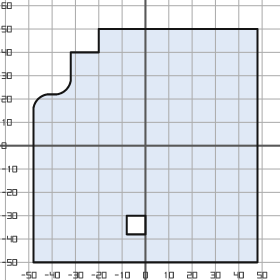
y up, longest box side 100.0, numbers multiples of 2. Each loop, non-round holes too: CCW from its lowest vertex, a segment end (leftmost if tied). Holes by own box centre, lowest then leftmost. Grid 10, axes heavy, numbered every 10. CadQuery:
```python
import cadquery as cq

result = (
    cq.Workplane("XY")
    .moveTo(-48.0, -50.0)
    .lineTo(48.0, -50.0)
    .lineTo(48.0, 50.0)
    .lineTo(-20.0, 50.0)
    .lineTo(-20.0, 40.0)
    .lineTo(-32.0, 40.0)
    .lineTo(-32.0, 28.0)
    .threePointArc((-34.0, 24.0), (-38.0, 22.0))
    .lineTo(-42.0, 22.0)
    .threePointArc((-46.0, 20.0), (-48.0, 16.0))
    .close()
    .moveTo(-8.0, -38.0)
    .lineTo(0.0, -38.0)
    .lineTo(0.0, -30.0)
    .lineTo(-8.0, -30.0)
    .close()
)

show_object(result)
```